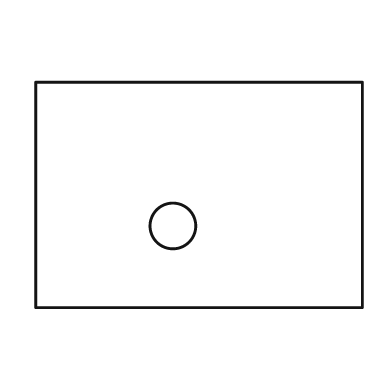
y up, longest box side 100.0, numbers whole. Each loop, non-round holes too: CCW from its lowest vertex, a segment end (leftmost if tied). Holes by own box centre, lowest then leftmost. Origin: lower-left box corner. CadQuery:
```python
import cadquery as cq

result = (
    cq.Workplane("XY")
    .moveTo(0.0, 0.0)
    .lineTo(100.0, 0.0)
    .lineTo(100.0, 69.0)
    .lineTo(0.0, 69.0)
    .close()
    .moveTo(42.0, 25.0)
    .circle(7.0)
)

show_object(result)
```